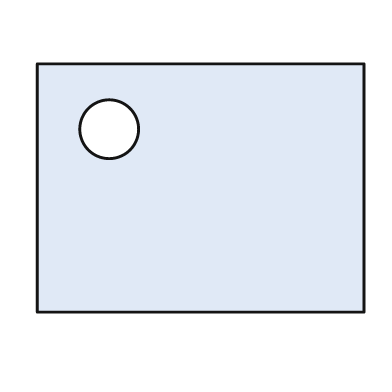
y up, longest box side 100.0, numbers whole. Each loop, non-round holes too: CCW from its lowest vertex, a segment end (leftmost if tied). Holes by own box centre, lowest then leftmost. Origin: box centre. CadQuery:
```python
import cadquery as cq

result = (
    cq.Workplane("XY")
    .moveTo(-50.0, -38.0)
    .lineTo(50.0, -38.0)
    .lineTo(50.0, 38.0)
    .lineTo(-50.0, 38.0)
    .close()
    .moveTo(-28.0, 18.0)
    .circle(9.0)
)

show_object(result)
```